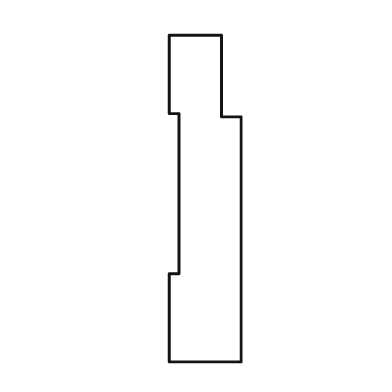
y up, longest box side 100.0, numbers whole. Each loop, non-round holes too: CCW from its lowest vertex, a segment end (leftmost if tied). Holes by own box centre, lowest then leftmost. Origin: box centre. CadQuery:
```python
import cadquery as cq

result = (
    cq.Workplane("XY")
    .moveTo(-11.0, -50.0)
    .lineTo(11.0, -50.0)
    .lineTo(11.0, 25.0)
    .lineTo(5.0, 25.0)
    .lineTo(5.0, 50.0)
    .lineTo(-11.0, 50.0)
    .lineTo(-11.0, 26.0)
    .lineTo(-8.0, 26.0)
    .lineTo(-8.0, -23.0)
    .lineTo(-11.0, -23.0)
    .close()
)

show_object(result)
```